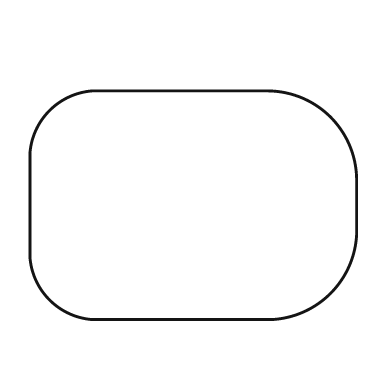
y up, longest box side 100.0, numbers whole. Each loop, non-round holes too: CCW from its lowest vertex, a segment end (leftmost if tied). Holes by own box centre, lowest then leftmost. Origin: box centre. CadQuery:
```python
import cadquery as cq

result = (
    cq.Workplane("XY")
    .moveTo(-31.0, -35.0)
    .lineTo(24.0, -35.0)
    .threePointArc((42.0, -27.0), (50.0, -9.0))
    .lineTo(50.0, 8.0)
    .threePointArc((42.0, 27.0), (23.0, 35.0))
    .lineTo(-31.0, 35.0)
    .threePointArc((-44.0, 29.0), (-50.0, 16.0))
    .lineTo(-50.0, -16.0)
    .threePointArc((-44.0, -29.0), (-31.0, -35.0))
    .close()
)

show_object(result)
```